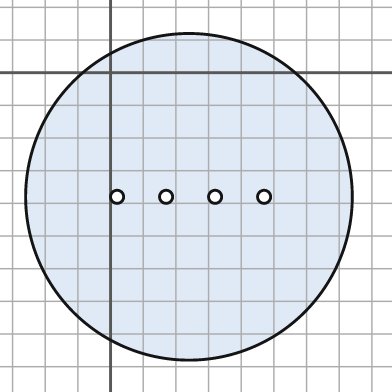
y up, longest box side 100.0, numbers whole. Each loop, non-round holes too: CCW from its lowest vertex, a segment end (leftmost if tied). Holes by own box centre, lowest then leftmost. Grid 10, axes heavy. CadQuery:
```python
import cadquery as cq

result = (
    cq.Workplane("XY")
    .moveTo(24.0, -38.0)
    .circle(50.0)
    .moveTo(2.0, -38.0)
    .circle(2.0)
    .moveTo(17.0, -38.0)
    .circle(2.0)
    .moveTo(32.0, -38.0)
    .circle(2.0)
    .moveTo(47.0, -38.0)
    .circle(2.0)
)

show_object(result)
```